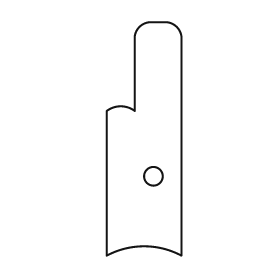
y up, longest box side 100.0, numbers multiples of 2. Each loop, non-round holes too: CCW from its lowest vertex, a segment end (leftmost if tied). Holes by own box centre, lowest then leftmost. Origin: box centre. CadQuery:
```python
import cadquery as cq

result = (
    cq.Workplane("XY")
    .moveTo(-16.0, -50.0)
    .threePointArc((0.0, -46.0), (16.0, -50.0))
    .lineTo(16.0, 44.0)
    .threePointArc((14.0, 48.0), (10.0, 50.0))
    .lineTo(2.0, 50.0)
    .threePointArc((-2.0, 48.0), (-4.0, 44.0))
    .lineTo(-4.0, 12.0)
    .threePointArc((-10.0, 14.0), (-16.0, 12.0))
    .close()
    .moveTo(4.0, -16.0)
    .circle(4.0)
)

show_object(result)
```